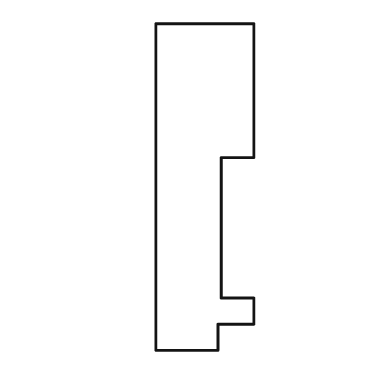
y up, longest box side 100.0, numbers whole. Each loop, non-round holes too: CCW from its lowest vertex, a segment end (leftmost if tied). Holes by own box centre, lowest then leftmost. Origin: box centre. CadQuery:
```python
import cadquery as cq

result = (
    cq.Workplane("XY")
    .moveTo(-15.0, -50.0)
    .lineTo(4.0, -50.0)
    .lineTo(4.0, -42.0)
    .lineTo(15.0, -42.0)
    .lineTo(15.0, -34.0)
    .lineTo(5.0, -34.0)
    .lineTo(5.0, 9.0)
    .lineTo(15.0, 9.0)
    .lineTo(15.0, 50.0)
    .lineTo(-15.0, 50.0)
    .close()
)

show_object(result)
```